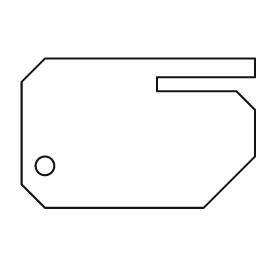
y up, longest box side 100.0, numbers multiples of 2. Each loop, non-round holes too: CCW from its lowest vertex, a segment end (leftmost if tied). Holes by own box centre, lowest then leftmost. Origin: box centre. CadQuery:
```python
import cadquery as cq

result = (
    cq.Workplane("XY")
    .moveTo(-40.0, -32.0)
    .lineTo(28.0, -32.0)
    .lineTo(50.0, -10.0)
    .lineTo(50.0, 10.0)
    .lineTo(42.0, 18.0)
    .lineTo(8.0, 18.0)
    .lineTo(8.0, 24.0)
    .lineTo(50.0, 24.0)
    .lineTo(50.0, 32.0)
    .lineTo(-40.0, 32.0)
    .lineTo(-50.0, 22.0)
    .lineTo(-50.0, -22.0)
    .close()
    .moveTo(-40.0, -14.0)
    .circle(4.0)
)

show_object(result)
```